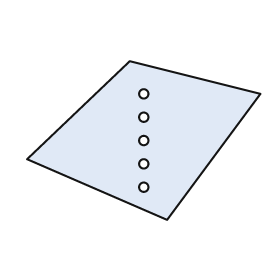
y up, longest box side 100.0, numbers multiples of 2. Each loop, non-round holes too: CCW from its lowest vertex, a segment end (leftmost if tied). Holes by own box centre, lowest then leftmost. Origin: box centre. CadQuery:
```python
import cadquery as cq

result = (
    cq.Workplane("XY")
    .moveTo(10.0, -34.0)
    .lineTo(50.0, 20.0)
    .lineTo(-6.0, 34.0)
    .lineTo(-50.0, -8.0)
    .close()
    .moveTo(0.0, -20.0)
    .circle(2.0)
    .moveTo(0.0, -10.0)
    .circle(2.0)
    .moveTo(0.0, 0.0)
    .circle(2.0)
    .moveTo(0.0, 10.0)
    .circle(2.0)
    .moveTo(0.0, 20.0)
    .circle(2.0)
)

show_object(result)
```